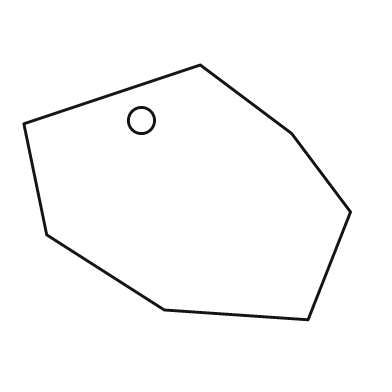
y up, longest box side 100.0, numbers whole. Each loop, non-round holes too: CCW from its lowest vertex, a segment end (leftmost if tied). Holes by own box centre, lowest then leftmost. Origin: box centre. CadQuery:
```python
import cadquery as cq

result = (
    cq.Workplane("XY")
    .moveTo(37.0, -39.0)
    .lineTo(50.0, -6.0)
    .lineTo(32.0, 18.0)
    .lineTo(4.0, 39.0)
    .lineTo(-50.0, 21.0)
    .lineTo(-43.0, -13.0)
    .lineTo(-7.0, -36.0)
    .close()
    .moveTo(-14.0, 22.0)
    .circle(4.0)
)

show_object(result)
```